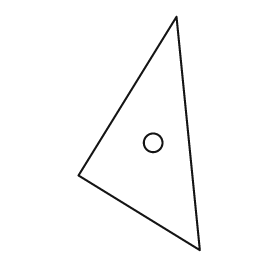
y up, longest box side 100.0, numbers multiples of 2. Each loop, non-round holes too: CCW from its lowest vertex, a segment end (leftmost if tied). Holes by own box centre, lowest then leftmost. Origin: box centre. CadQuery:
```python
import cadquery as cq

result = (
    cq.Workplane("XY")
    .moveTo(26.0, -50.0)
    .lineTo(16.0, 50.0)
    .lineTo(-26.0, -18.0)
    .close()
    .moveTo(6.0, -4.0)
    .circle(4.0)
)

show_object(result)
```